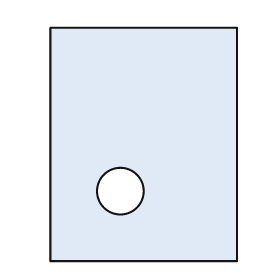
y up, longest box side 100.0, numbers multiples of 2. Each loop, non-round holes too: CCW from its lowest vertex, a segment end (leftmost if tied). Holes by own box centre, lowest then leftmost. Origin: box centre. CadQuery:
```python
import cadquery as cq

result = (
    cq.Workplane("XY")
    .moveTo(-40.0, -50.0)
    .lineTo(40.0, -50.0)
    .lineTo(40.0, 50.0)
    .lineTo(-40.0, 50.0)
    .close()
    .moveTo(-10.0, -20.0)
    .circle(10.0)
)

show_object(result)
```